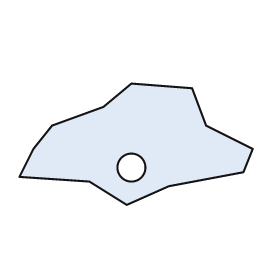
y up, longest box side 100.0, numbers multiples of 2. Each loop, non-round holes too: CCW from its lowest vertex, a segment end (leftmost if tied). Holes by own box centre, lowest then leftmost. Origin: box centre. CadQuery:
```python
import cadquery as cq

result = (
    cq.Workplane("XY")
    .moveTo(-4.0, -26.0)
    .lineTo(14.0, -18.0)
    .lineTo(46.0, -12.0)
    .lineTo(50.0, -2.0)
    .lineTo(30.0, 8.0)
    .lineTo(24.0, 24.0)
    .lineTo(-2.0, 26.0)
    .lineTo(-14.0, 16.0)
    .lineTo(-36.0, 8.0)
    .lineTo(-44.0, -2.0)
    .lineTo(-50.0, -14.0)
    .lineTo(-20.0, -16.0)
    .close()
    .moveTo(-2.0, -10.0)
    .circle(6.0)
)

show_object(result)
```